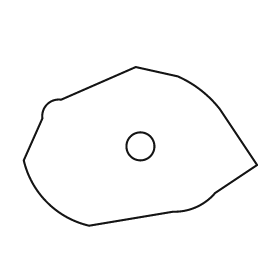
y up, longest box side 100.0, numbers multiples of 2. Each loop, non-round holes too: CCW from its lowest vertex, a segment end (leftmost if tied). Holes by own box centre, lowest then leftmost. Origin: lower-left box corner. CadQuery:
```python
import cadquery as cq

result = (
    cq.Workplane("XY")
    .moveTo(28.0, 0.0)
    .lineTo(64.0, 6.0)
    .threePointArc((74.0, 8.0), (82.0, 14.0))
    .lineTo(100.0, 26.0)
    .lineTo(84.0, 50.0)
    .threePointArc((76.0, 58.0), (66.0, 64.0))
    .lineTo(48.0, 68.0)
    .lineTo(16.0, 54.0)
    .threePointArc((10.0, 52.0), (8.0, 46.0))
    .lineTo(0.0, 28.0)
    .threePointArc((10.0, 10.0), (28.0, 0.0))
    .close()
    .moveTo(50.0, 34.0)
    .circle(6.0)
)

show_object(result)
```